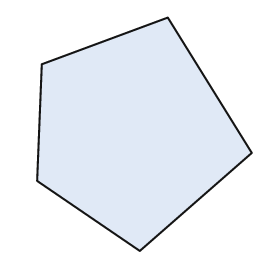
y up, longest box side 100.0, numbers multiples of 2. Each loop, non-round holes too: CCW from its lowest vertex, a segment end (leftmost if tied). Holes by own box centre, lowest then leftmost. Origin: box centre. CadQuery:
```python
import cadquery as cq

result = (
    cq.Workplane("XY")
    .moveTo(-2.0, -50.0)
    .lineTo(46.0, -8.0)
    .lineTo(10.0, 50.0)
    .lineTo(-44.0, 30.0)
    .lineTo(-46.0, -20.0)
    .close()
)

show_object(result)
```